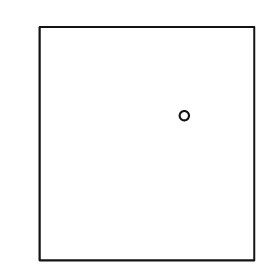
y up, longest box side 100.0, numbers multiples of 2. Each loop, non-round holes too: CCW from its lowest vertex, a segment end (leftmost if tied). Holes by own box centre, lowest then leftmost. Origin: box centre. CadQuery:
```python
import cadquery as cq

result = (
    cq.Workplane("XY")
    .moveTo(-46.0, -50.0)
    .lineTo(46.0, -50.0)
    .lineTo(46.0, 50.0)
    .lineTo(-46.0, 50.0)
    .close()
    .moveTo(16.0, 12.0)
    .circle(2.0)
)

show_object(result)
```